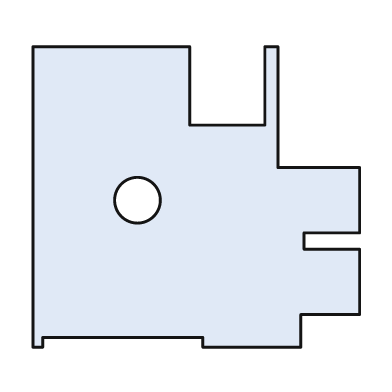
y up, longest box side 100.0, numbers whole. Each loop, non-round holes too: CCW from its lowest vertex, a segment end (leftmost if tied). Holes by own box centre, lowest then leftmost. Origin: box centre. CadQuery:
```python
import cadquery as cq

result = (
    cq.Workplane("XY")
    .moveTo(-50.0, -46.0)
    .lineTo(-47.0, -46.0)
    .lineTo(-47.0, -43.0)
    .lineTo(2.0, -43.0)
    .lineTo(2.0, -46.0)
    .lineTo(32.0, -46.0)
    .lineTo(32.0, -36.0)
    .lineTo(50.0, -36.0)
    .lineTo(50.0, -16.0)
    .lineTo(33.0, -16.0)
    .lineTo(33.0, -11.0)
    .lineTo(50.0, -11.0)
    .lineTo(50.0, 9.0)
    .lineTo(25.0, 9.0)
    .lineTo(25.0, 46.0)
    .lineTo(21.0, 46.0)
    .lineTo(21.0, 22.0)
    .lineTo(-2.0, 22.0)
    .lineTo(-2.0, 46.0)
    .lineTo(-50.0, 46.0)
    .close()
    .moveTo(-18.0, -1.0)
    .circle(7.0)
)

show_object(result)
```